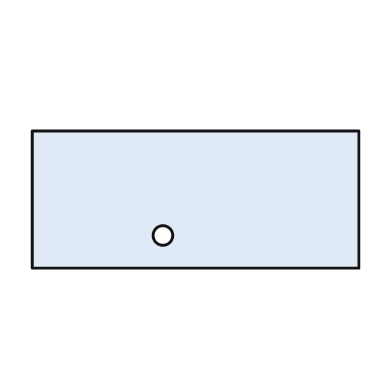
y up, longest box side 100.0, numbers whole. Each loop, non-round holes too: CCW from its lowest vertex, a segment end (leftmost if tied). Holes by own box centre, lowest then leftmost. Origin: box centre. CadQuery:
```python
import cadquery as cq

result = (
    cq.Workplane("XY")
    .moveTo(-50.0, -21.0)
    .lineTo(50.0, -21.0)
    .lineTo(50.0, 21.0)
    .lineTo(-50.0, 21.0)
    .close()
    .moveTo(-10.0, -11.0)
    .circle(3.0)
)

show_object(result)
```